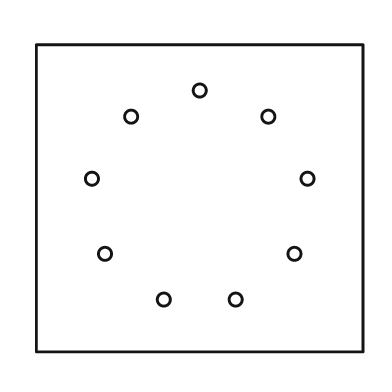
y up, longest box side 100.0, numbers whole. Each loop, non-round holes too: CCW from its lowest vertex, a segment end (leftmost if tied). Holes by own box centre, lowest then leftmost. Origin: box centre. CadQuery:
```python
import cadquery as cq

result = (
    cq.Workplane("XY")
    .moveTo(-50.0, -47.0)
    .lineTo(50.0, -47.0)
    .lineTo(50.0, 47.0)
    .lineTo(-50.0, 47.0)
    .close()
    .moveTo(-11.0, -31.0)
    .circle(2.0)
    .moveTo(11.0, -31.0)
    .circle(2.0)
    .moveTo(-29.0, -17.0)
    .circle(2.0)
    .moveTo(29.0, -17.0)
    .circle(2.0)
    .moveTo(-33.0, 6.0)
    .circle(2.0)
    .moveTo(33.0, 6.0)
    .circle(2.0)
    .moveTo(-21.0, 25.0)
    .circle(2.0)
    .moveTo(21.0, 25.0)
    .circle(2.0)
    .moveTo(0.0, 33.0)
    .circle(2.0)
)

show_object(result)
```